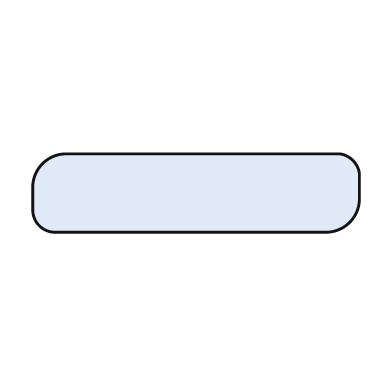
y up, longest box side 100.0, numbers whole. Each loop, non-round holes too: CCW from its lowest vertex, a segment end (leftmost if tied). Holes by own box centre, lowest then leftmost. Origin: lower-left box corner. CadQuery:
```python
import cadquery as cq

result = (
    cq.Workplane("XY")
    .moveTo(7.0, 0.0)
    .lineTo(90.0, 0.0)
    .threePointArc((97.0, 3.0), (100.0, 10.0))
    .lineTo(100.0, 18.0)
    .threePointArc((98.0, 22.0), (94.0, 24.0))
    .lineTo(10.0, 24.0)
    .threePointArc((3.0, 21.0), (0.0, 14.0))
    .lineTo(0.0, 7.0)
    .threePointArc((2.0, 2.0), (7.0, 0.0))
    .close()
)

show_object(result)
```